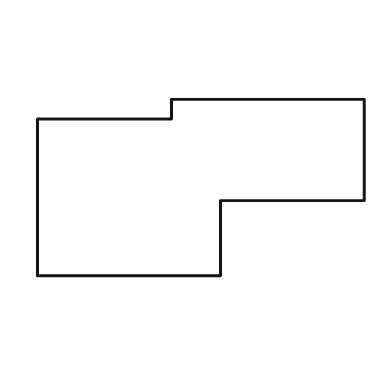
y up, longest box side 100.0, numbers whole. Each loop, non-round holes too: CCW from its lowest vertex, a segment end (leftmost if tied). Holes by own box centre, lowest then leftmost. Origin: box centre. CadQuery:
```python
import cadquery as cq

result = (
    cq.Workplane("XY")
    .moveTo(-50.0, -27.0)
    .lineTo(6.0, -27.0)
    .lineTo(6.0, -4.0)
    .lineTo(50.0, -4.0)
    .lineTo(50.0, 27.0)
    .lineTo(-9.0, 27.0)
    .lineTo(-9.0, 21.0)
    .lineTo(-50.0, 21.0)
    .close()
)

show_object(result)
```